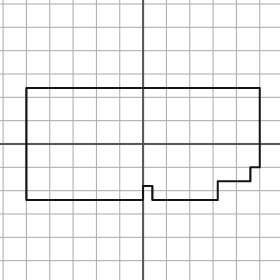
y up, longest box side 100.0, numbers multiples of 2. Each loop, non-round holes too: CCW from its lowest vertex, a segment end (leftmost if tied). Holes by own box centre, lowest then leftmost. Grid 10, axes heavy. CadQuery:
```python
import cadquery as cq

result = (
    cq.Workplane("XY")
    .moveTo(-50.0, -24.0)
    .lineTo(0.0, -24.0)
    .lineTo(0.0, -18.0)
    .lineTo(4.0, -18.0)
    .lineTo(4.0, -24.0)
    .lineTo(32.0, -24.0)
    .lineTo(32.0, -16.0)
    .lineTo(46.0, -16.0)
    .lineTo(46.0, -10.0)
    .lineTo(50.0, -10.0)
    .lineTo(50.0, 24.0)
    .lineTo(-50.0, 24.0)
    .close()
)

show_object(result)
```